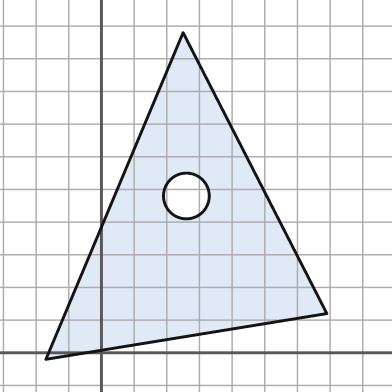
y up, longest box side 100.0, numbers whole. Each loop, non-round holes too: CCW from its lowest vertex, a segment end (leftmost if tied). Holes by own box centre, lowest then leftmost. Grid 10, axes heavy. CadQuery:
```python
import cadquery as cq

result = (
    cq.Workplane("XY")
    .moveTo(-17.0, -2.0)
    .lineTo(69.0, 12.0)
    .lineTo(25.0, 98.0)
    .close()
    .moveTo(26.0, 48.0)
    .circle(7.0)
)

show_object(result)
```